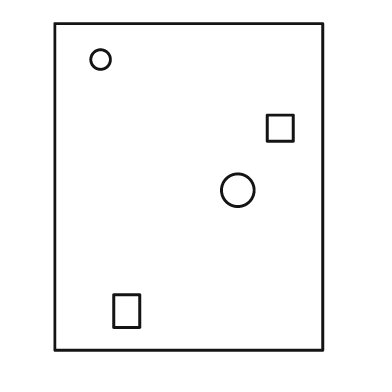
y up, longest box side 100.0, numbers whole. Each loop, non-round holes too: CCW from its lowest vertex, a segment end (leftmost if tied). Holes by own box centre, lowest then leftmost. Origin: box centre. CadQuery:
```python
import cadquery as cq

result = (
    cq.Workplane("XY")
    .moveTo(-41.0, -50.0)
    .lineTo(41.0, -50.0)
    .lineTo(41.0, 50.0)
    .lineTo(-41.0, 50.0)
    .close()
    .moveTo(-23.0, -43.0)
    .lineTo(-15.0, -43.0)
    .lineTo(-15.0, -33.0)
    .lineTo(-23.0, -33.0)
    .close()
    .moveTo(15.0, -1.0)
    .circle(5.0)
    .moveTo(24.0, 14.0)
    .lineTo(32.0, 14.0)
    .lineTo(32.0, 22.0)
    .lineTo(24.0, 22.0)
    .close()
    .moveTo(-27.0, 39.0)
    .circle(3.0)
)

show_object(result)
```